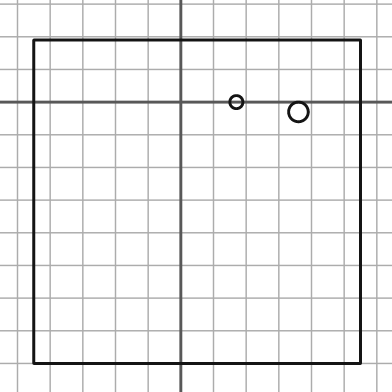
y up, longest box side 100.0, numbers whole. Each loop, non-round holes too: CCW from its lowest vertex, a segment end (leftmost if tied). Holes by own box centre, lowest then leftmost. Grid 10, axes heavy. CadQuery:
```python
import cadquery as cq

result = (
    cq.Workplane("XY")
    .moveTo(-45.0, -80.0)
    .lineTo(55.0, -80.0)
    .lineTo(55.0, 19.0)
    .lineTo(-45.0, 19.0)
    .close()
    .moveTo(36.0, -3.0)
    .circle(3.0)
    .moveTo(17.0, 0.0)
    .circle(2.0)
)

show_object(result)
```